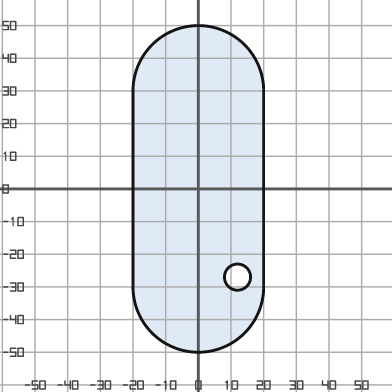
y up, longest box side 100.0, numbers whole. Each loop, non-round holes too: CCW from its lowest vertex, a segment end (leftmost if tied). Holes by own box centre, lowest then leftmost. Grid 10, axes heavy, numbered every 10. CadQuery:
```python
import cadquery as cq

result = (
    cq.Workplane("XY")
    .moveTo(-20.0, -30.0)
    .threePointArc((0.0, -50.0), (20.0, -30.0))
    .lineTo(20.0, 30.0)
    .threePointArc((0.0, 50.0), (-20.0, 30.0))
    .close()
    .moveTo(12.0, -27.0)
    .circle(4.0)
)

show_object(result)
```